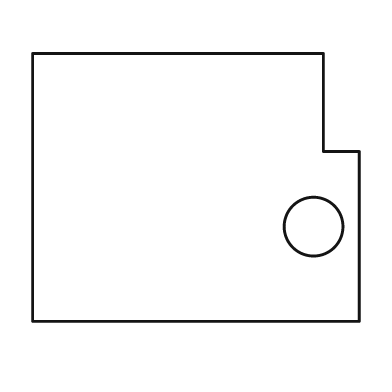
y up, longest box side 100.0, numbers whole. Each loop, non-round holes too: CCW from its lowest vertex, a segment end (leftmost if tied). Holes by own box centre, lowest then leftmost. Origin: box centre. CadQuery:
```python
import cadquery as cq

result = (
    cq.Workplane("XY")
    .moveTo(-50.0, -41.0)
    .lineTo(50.0, -41.0)
    .lineTo(50.0, 11.0)
    .lineTo(39.0, 11.0)
    .lineTo(39.0, 41.0)
    .lineTo(-50.0, 41.0)
    .close()
    .moveTo(36.0, -12.0)
    .circle(9.0)
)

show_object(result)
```